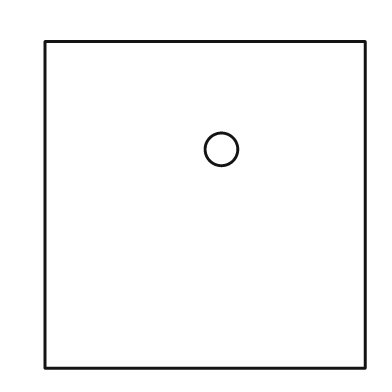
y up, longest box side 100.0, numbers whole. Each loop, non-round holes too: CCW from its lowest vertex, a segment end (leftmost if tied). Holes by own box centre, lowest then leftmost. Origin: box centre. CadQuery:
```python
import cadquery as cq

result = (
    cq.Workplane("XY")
    .moveTo(-49.0, -50.0)
    .lineTo(49.0, -50.0)
    .lineTo(49.0, 50.0)
    .lineTo(-49.0, 50.0)
    .close()
    .moveTo(5.0, 17.0)
    .circle(5.0)
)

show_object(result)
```